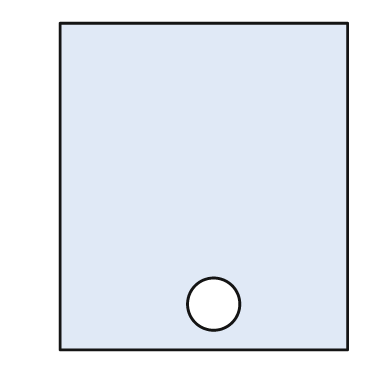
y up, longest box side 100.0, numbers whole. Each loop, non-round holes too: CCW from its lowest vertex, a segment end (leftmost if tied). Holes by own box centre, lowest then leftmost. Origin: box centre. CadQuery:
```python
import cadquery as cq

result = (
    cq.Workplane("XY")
    .moveTo(-44.0, -50.0)
    .lineTo(44.0, -50.0)
    .lineTo(44.0, 50.0)
    .lineTo(-44.0, 50.0)
    .close()
    .moveTo(3.0, -36.0)
    .circle(8.0)
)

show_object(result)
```